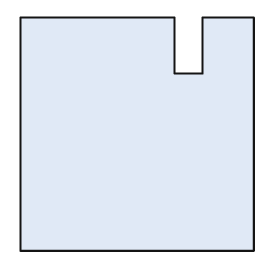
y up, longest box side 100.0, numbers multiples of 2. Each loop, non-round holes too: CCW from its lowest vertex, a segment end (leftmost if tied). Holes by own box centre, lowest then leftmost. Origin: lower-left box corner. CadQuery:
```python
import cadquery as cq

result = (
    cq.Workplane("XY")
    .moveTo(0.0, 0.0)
    .lineTo(100.0, 0.0)
    .lineTo(100.0, 100.0)
    .lineTo(78.0, 100.0)
    .lineTo(78.0, 76.0)
    .lineTo(66.0, 76.0)
    .lineTo(66.0, 100.0)
    .lineTo(0.0, 100.0)
    .close()
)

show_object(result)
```